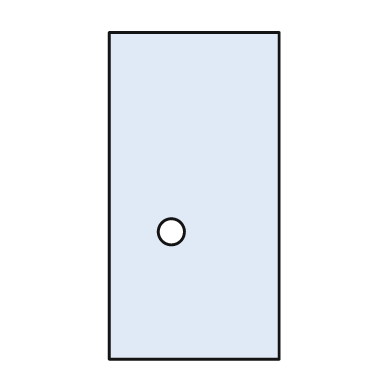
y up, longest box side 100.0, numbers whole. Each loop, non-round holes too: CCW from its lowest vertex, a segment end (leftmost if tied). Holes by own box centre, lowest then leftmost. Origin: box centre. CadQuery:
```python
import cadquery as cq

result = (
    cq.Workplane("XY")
    .moveTo(-26.0, -50.0)
    .lineTo(26.0, -50.0)
    .lineTo(26.0, 50.0)
    .lineTo(-26.0, 50.0)
    .close()
    .moveTo(-7.0, -11.0)
    .circle(4.0)
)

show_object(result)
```